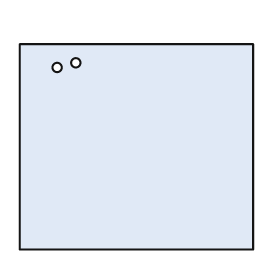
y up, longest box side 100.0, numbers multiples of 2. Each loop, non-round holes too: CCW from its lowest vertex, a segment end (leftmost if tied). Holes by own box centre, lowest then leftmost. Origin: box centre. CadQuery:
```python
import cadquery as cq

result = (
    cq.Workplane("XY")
    .moveTo(-50.0, -44.0)
    .lineTo(50.0, -44.0)
    .lineTo(50.0, 44.0)
    .lineTo(-50.0, 44.0)
    .close()
    .moveTo(-34.0, 34.0)
    .circle(2.0)
    .moveTo(-26.0, 36.0)
    .circle(2.0)
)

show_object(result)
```